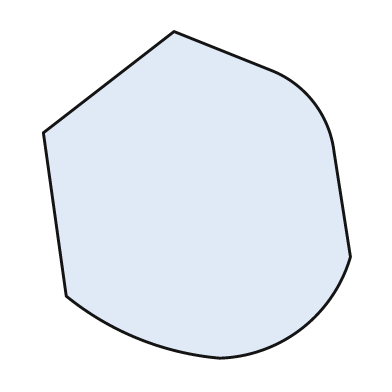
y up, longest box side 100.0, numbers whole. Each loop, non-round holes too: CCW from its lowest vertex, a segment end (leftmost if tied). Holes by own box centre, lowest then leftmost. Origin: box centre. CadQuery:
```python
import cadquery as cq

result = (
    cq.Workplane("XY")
    .moveTo(7.0, -50.0)
    .threePointArc((32.0, -41.0), (47.0, -19.0))
    .lineTo(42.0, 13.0)
    .threePointArc((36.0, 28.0), (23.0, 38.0))
    .lineTo(-7.0, 50.0)
    .lineTo(-47.0, 19.0)
    .lineTo(-40.0, -31.0)
    .threePointArc((-18.0, -44.0), (7.0, -50.0))
    .close()
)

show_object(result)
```